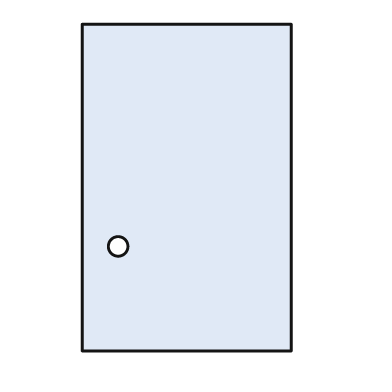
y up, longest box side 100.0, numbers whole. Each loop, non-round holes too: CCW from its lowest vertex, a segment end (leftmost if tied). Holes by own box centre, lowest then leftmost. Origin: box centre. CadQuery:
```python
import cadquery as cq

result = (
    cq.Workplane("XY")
    .moveTo(-32.0, -50.0)
    .lineTo(32.0, -50.0)
    .lineTo(32.0, 50.0)
    .lineTo(-32.0, 50.0)
    .close()
    .moveTo(-21.0, -18.0)
    .circle(3.0)
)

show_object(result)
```